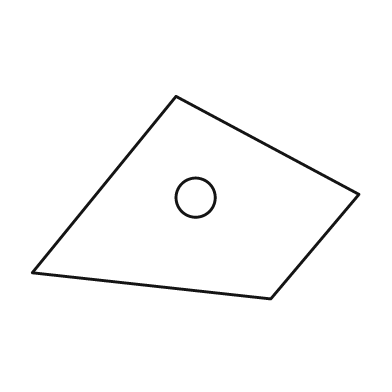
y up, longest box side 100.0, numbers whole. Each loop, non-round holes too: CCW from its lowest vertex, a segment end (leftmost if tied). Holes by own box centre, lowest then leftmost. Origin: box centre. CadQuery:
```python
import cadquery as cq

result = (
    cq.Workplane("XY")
    .moveTo(23.0, -31.0)
    .lineTo(50.0, 1.0)
    .lineTo(-6.0, 31.0)
    .lineTo(-50.0, -23.0)
    .close()
    .moveTo(0.0, 0.0)
    .circle(6.0)
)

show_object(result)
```